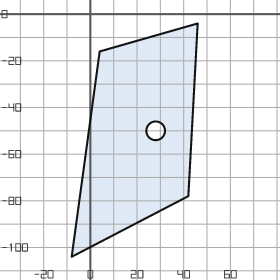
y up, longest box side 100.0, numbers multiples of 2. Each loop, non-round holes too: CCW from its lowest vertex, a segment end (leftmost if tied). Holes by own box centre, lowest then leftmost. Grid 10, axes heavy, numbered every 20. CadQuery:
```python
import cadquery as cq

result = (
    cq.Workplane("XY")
    .moveTo(-8.0, -104.0)
    .lineTo(42.0, -78.0)
    .lineTo(46.0, -4.0)
    .lineTo(4.0, -16.0)
    .close()
    .moveTo(28.0, -50.0)
    .circle(4.0)
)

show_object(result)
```